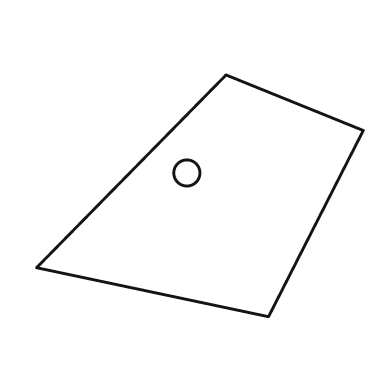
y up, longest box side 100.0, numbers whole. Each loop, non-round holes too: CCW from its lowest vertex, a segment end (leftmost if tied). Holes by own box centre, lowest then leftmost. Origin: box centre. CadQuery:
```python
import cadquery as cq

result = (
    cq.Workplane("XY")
    .moveTo(21.0, -37.0)
    .lineTo(50.0, 20.0)
    .lineTo(8.0, 37.0)
    .lineTo(-50.0, -22.0)
    .close()
    .moveTo(-4.0, 7.0)
    .circle(4.0)
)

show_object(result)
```